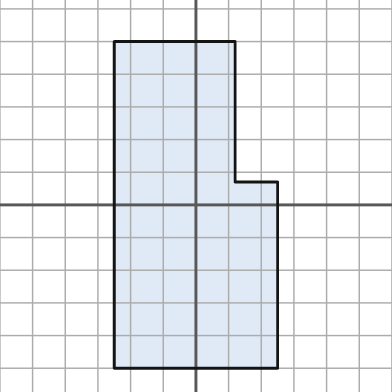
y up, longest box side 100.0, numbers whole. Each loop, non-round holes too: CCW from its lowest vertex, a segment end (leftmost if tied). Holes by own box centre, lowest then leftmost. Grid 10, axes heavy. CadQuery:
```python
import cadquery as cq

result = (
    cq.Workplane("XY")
    .moveTo(-25.0, -50.0)
    .lineTo(25.0, -50.0)
    .lineTo(25.0, 7.0)
    .lineTo(12.0, 7.0)
    .lineTo(12.0, 50.0)
    .lineTo(-25.0, 50.0)
    .close()
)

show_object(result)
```